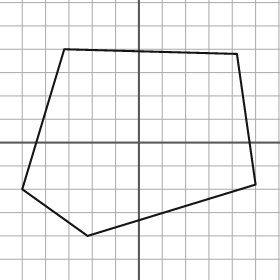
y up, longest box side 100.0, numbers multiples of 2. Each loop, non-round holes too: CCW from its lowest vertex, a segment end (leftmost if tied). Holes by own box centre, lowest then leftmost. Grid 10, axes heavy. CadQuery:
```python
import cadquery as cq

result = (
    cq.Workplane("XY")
    .moveTo(-22.0, -40.0)
    .lineTo(50.0, -18.0)
    .lineTo(42.0, 38.0)
    .lineTo(-32.0, 40.0)
    .lineTo(-50.0, -20.0)
    .close()
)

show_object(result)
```